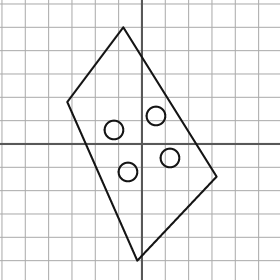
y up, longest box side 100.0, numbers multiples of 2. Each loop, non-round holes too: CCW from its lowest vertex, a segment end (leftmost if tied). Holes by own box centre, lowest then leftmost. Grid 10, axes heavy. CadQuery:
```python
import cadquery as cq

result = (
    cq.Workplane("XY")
    .moveTo(-2.0, -50.0)
    .lineTo(32.0, -14.0)
    .lineTo(-8.0, 50.0)
    .lineTo(-32.0, 18.0)
    .close()
    .moveTo(-6.0, -12.0)
    .circle(4.0)
    .moveTo(12.0, -6.0)
    .circle(4.0)
    .moveTo(-12.0, 6.0)
    .circle(4.0)
    .moveTo(6.0, 12.0)
    .circle(4.0)
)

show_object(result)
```